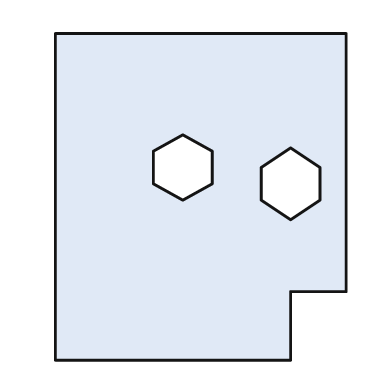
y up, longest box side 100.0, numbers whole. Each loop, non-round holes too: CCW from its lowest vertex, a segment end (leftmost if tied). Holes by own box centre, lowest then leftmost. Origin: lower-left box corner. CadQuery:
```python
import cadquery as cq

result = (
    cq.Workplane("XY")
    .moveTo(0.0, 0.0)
    .lineTo(72.0, 0.0)
    .lineTo(72.0, 21.0)
    .lineTo(89.0, 21.0)
    .lineTo(89.0, 100.0)
    .lineTo(0.0, 100.0)
    .close()
    .moveTo(72.0, 43.0)
    .lineTo(81.0, 49.0)
    .lineTo(81.0, 59.0)
    .lineTo(72.0, 65.0)
    .lineTo(63.0, 59.0)
    .lineTo(63.0, 49.0)
    .close()
    .moveTo(39.0, 49.0)
    .lineTo(48.0, 54.0)
    .lineTo(48.0, 64.0)
    .lineTo(39.0, 69.0)
    .lineTo(30.0, 64.0)
    .lineTo(30.0, 54.0)
    .close()
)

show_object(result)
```